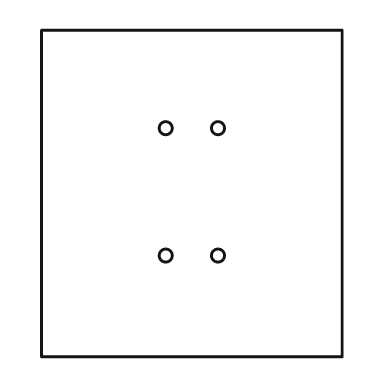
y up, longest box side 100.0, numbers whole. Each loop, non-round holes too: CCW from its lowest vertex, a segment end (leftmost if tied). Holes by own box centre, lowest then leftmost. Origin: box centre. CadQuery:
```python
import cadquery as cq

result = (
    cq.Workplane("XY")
    .moveTo(-46.0, -50.0)
    .lineTo(46.0, -50.0)
    .lineTo(46.0, 50.0)
    .lineTo(-46.0, 50.0)
    .close()
    .moveTo(-8.0, -19.0)
    .circle(2.0)
    .moveTo(8.0, -19.0)
    .circle(2.0)
    .moveTo(-8.0, 20.0)
    .circle(2.0)
    .moveTo(8.0, 20.0)
    .circle(2.0)
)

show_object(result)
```